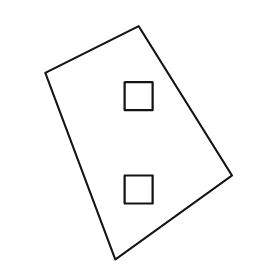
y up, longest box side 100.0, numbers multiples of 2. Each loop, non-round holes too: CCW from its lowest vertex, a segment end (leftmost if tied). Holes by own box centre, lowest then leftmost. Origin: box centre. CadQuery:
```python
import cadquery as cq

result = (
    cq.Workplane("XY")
    .moveTo(-10.0, -50.0)
    .lineTo(40.0, -14.0)
    .lineTo(0.0, 50.0)
    .lineTo(-40.0, 30.0)
    .close()
    .moveTo(-6.0, -26.0)
    .lineTo(6.0, -26.0)
    .lineTo(6.0, -14.0)
    .lineTo(-6.0, -14.0)
    .close()
    .moveTo(-6.0, 14.0)
    .lineTo(6.0, 14.0)
    .lineTo(6.0, 26.0)
    .lineTo(-6.0, 26.0)
    .close()
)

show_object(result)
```